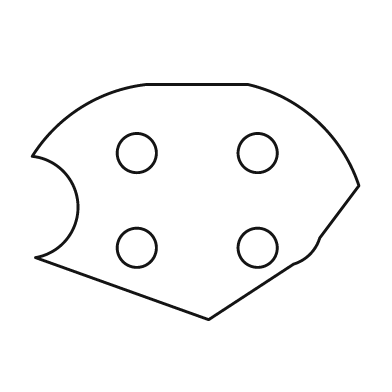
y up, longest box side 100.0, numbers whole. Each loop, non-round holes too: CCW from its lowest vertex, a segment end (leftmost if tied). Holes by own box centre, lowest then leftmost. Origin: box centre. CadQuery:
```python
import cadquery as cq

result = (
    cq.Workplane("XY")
    .moveTo(4.0, -36.0)
    .lineTo(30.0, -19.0)
    .threePointArc((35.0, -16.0), (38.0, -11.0))
    .lineTo(50.0, 5.0)
    .threePointArc((37.0, 25.0), (16.0, 36.0))
    .lineTo(-15.0, 36.0)
    .threePointArc((-35.0, 29.0), (-50.0, 14.0))
    .threePointArc((-36.0, -1.0), (-49.0, -17.0))
    .close()
    .moveTo(-18.0, -14.0)
    .circle(6.0)
    .moveTo(19.0, -14.0)
    .circle(6.0)
    .moveTo(-18.0, 15.0)
    .circle(6.0)
    .moveTo(19.0, 15.0)
    .circle(6.0)
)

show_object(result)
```